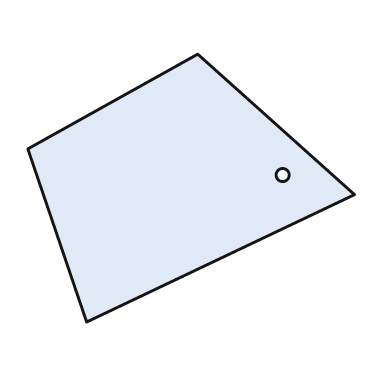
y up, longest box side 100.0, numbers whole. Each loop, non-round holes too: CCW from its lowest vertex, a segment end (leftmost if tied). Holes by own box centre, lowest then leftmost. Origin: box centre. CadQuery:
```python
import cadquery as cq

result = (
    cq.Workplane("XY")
    .moveTo(-32.0, -41.0)
    .lineTo(50.0, -2.0)
    .lineTo(2.0, 41.0)
    .lineTo(-50.0, 12.0)
    .close()
    .moveTo(28.0, 4.0)
    .circle(2.0)
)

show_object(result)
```